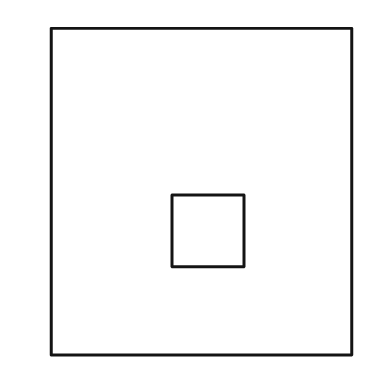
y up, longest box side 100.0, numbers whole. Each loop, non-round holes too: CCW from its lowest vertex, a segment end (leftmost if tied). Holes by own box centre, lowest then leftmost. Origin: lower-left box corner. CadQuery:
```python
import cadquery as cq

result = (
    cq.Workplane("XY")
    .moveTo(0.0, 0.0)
    .lineTo(92.0, 0.0)
    .lineTo(92.0, 100.0)
    .lineTo(0.0, 100.0)
    .close()
    .moveTo(37.0, 27.0)
    .lineTo(59.0, 27.0)
    .lineTo(59.0, 49.0)
    .lineTo(37.0, 49.0)
    .close()
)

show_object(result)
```